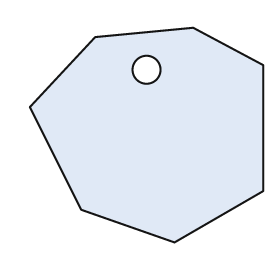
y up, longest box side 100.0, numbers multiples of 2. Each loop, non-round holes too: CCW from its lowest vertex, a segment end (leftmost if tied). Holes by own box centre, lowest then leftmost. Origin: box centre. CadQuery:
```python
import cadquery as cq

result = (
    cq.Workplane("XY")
    .moveTo(12.0, -46.0)
    .lineTo(50.0, -24.0)
    .lineTo(50.0, 30.0)
    .lineTo(20.0, 46.0)
    .lineTo(-22.0, 42.0)
    .lineTo(-50.0, 12.0)
    .lineTo(-28.0, -32.0)
    .close()
    .moveTo(0.0, 28.0)
    .circle(6.0)
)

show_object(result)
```